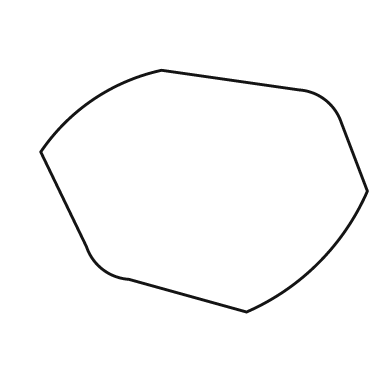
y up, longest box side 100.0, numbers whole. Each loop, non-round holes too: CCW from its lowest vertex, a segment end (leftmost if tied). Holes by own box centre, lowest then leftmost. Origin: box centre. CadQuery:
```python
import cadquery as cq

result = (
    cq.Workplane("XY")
    .moveTo(13.0, -37.0)
    .threePointArc((35.0, -22.0), (50.0, 0.0))
    .lineTo(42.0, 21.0)
    .threePointArc((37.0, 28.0), (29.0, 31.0))
    .lineTo(-13.0, 37.0)
    .threePointArc((-34.0, 28.0), (-50.0, 12.0))
    .lineTo(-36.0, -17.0)
    .threePointArc((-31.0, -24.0), (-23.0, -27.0))
    .close()
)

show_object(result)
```